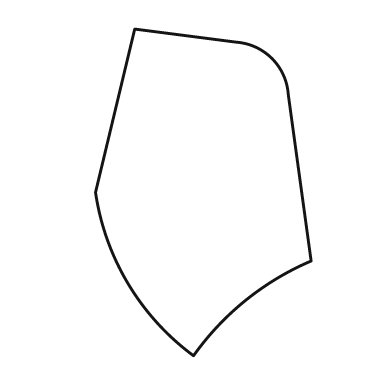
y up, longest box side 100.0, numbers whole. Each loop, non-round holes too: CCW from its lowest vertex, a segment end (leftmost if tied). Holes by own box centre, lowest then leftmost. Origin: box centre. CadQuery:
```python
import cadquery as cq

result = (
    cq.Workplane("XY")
    .moveTo(-3.0, -50.0)
    .threePointArc((13.0, -33.0), (33.0, -21.0))
    .lineTo(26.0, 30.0)
    .threePointArc((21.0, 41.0), (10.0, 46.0))
    .lineTo(-21.0, 50.0)
    .lineTo(-33.0, 0.0)
    .threePointArc((-23.0, -28.0), (-3.0, -50.0))
    .close()
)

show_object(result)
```